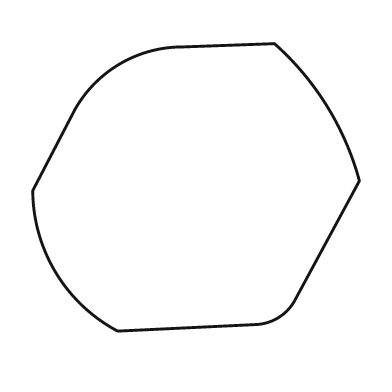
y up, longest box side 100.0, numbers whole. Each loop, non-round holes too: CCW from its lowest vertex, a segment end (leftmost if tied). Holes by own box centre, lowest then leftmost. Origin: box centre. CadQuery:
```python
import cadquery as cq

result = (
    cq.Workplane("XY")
    .moveTo(-24.0, -44.0)
    .lineTo(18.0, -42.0)
    .threePointArc((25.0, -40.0), (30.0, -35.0))
    .lineTo(50.0, 2.0)
    .threePointArc((40.0, 25.0), (24.0, 44.0))
    .lineTo(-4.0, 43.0)
    .threePointArc((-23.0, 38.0), (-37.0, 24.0))
    .lineTo(-50.0, -1.0)
    .threePointArc((-43.0, -26.0), (-24.0, -44.0))
    .close()
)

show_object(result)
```